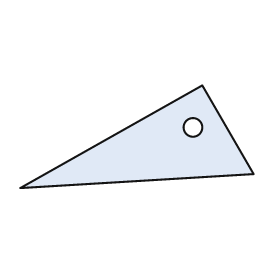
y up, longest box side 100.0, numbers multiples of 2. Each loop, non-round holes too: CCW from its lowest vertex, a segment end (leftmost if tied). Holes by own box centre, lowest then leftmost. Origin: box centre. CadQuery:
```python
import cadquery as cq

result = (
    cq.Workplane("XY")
    .moveTo(-50.0, -22.0)
    .lineTo(50.0, -16.0)
    .lineTo(28.0, 22.0)
    .close()
    .moveTo(24.0, 4.0)
    .circle(4.0)
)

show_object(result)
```